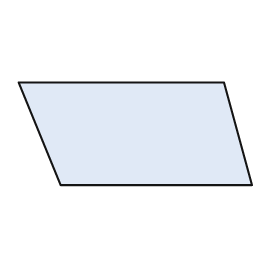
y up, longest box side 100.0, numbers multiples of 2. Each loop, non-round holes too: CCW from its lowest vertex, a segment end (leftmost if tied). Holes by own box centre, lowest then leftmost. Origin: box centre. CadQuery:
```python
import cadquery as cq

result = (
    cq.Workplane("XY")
    .moveTo(-32.0, -22.0)
    .lineTo(50.0, -22.0)
    .lineTo(38.0, 22.0)
    .lineTo(-50.0, 22.0)
    .close()
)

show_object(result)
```